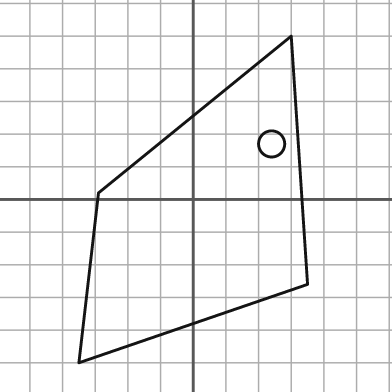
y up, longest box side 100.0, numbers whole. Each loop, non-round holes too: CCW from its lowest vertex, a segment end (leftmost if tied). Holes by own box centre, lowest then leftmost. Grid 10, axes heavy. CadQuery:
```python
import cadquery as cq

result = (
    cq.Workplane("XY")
    .moveTo(-35.0, -50.0)
    .lineTo(35.0, -26.0)
    .lineTo(30.0, 50.0)
    .lineTo(-29.0, 2.0)
    .close()
    .moveTo(24.0, 17.0)
    .circle(4.0)
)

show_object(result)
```